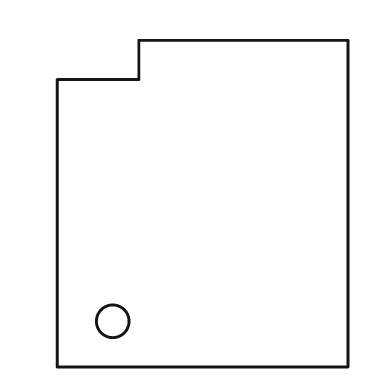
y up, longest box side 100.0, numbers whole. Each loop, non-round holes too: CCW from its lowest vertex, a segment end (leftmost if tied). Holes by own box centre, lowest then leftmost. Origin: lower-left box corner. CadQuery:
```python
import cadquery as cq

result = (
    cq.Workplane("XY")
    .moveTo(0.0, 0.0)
    .lineTo(89.0, 0.0)
    .lineTo(89.0, 100.0)
    .lineTo(25.0, 100.0)
    .lineTo(25.0, 88.0)
    .lineTo(0.0, 88.0)
    .close()
    .moveTo(17.0, 14.0)
    .circle(5.0)
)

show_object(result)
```